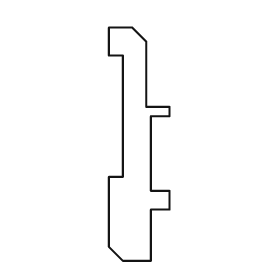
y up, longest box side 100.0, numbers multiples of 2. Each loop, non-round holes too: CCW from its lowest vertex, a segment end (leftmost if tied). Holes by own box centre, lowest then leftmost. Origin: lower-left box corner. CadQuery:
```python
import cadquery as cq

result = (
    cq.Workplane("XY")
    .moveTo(6.0, 0.0)
    .lineTo(18.0, 0.0)
    .lineTo(18.0, 22.0)
    .lineTo(26.0, 22.0)
    .lineTo(26.0, 30.0)
    .lineTo(18.0, 30.0)
    .lineTo(18.0, 62.0)
    .lineTo(26.0, 62.0)
    .lineTo(26.0, 66.0)
    .lineTo(16.0, 66.0)
    .lineTo(16.0, 94.0)
    .lineTo(10.0, 100.0)
    .lineTo(0.0, 100.0)
    .lineTo(0.0, 88.0)
    .lineTo(6.0, 88.0)
    .lineTo(6.0, 36.0)
    .lineTo(0.0, 36.0)
    .lineTo(0.0, 6.0)
    .close()
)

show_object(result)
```